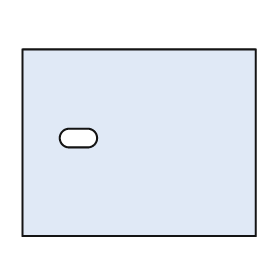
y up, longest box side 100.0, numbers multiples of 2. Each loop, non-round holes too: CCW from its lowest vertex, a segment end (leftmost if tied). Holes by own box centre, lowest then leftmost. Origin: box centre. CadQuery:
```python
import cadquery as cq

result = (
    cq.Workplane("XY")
    .moveTo(-50.0, -40.0)
    .lineTo(50.0, -40.0)
    .lineTo(50.0, 40.0)
    .lineTo(-50.0, 40.0)
    .close()
    .moveTo(-30.0, -2.0)
    .lineTo(-22.0, -2.0)
    .threePointArc((-18.0, 2.0), (-22.0, 6.0))
    .lineTo(-30.0, 6.0)
    .threePointArc((-34.0, 2.0), (-30.0, -2.0))
    .close()
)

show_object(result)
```